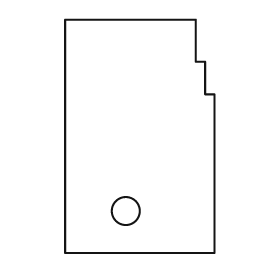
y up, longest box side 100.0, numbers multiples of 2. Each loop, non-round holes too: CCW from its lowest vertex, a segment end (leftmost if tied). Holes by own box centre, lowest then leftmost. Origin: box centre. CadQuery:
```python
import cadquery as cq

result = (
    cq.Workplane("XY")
    .moveTo(-32.0, -50.0)
    .lineTo(32.0, -50.0)
    .lineTo(32.0, 18.0)
    .lineTo(28.0, 18.0)
    .lineTo(28.0, 32.0)
    .lineTo(24.0, 32.0)
    .lineTo(24.0, 50.0)
    .lineTo(-32.0, 50.0)
    .close()
    .moveTo(-6.0, -32.0)
    .circle(6.0)
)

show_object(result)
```